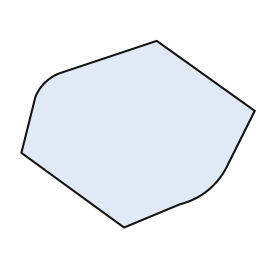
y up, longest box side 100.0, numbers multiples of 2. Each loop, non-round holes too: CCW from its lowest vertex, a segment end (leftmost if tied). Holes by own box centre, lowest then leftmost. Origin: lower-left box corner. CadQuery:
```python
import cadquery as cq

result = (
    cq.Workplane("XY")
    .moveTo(44.0, 0.0)
    .lineTo(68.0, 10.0)
    .threePointArc((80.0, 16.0), (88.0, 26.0))
    .lineTo(100.0, 50.0)
    .lineTo(58.0, 80.0)
    .lineTo(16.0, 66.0)
    .threePointArc((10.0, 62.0), (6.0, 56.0))
    .lineTo(0.0, 32.0)
    .close()
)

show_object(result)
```